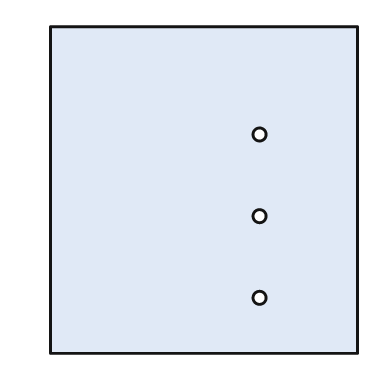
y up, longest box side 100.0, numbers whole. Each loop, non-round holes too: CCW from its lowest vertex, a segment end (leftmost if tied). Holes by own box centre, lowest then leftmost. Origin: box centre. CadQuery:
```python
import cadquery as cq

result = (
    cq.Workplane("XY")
    .moveTo(-47.0, -50.0)
    .lineTo(47.0, -50.0)
    .lineTo(47.0, 50.0)
    .lineTo(-47.0, 50.0)
    .close()
    .moveTo(17.0, -33.0)
    .circle(2.0)
    .moveTo(17.0, -8.0)
    .circle(2.0)
    .moveTo(17.0, 17.0)
    .circle(2.0)
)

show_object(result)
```